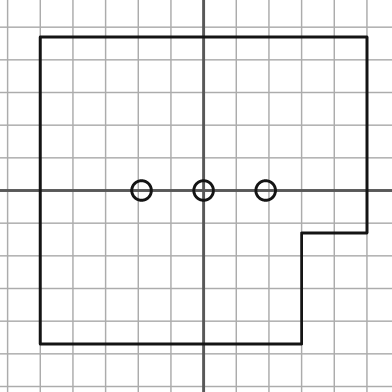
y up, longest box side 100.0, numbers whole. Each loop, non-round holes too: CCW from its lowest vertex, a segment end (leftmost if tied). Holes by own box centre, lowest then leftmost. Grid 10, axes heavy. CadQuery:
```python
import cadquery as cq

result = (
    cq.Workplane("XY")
    .moveTo(-50.0, -47.0)
    .lineTo(30.0, -47.0)
    .lineTo(30.0, -13.0)
    .lineTo(50.0, -13.0)
    .lineTo(50.0, 47.0)
    .lineTo(-50.0, 47.0)
    .close()
    .moveTo(-19.0, 0.0)
    .circle(3.0)
    .moveTo(0.0, 0.0)
    .circle(3.0)
    .moveTo(19.0, 0.0)
    .circle(3.0)
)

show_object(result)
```